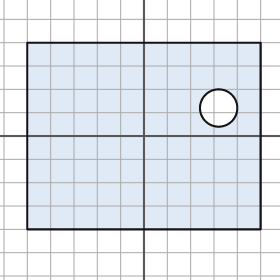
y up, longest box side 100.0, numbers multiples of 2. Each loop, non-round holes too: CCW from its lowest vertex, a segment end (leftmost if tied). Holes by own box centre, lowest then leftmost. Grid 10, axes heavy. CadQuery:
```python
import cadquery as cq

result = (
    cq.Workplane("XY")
    .moveTo(-50.0, -40.0)
    .lineTo(50.0, -40.0)
    .lineTo(50.0, 40.0)
    .lineTo(-50.0, 40.0)
    .close()
    .moveTo(32.0, 12.0)
    .circle(8.0)
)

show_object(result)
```